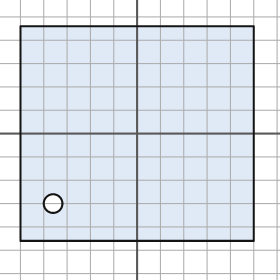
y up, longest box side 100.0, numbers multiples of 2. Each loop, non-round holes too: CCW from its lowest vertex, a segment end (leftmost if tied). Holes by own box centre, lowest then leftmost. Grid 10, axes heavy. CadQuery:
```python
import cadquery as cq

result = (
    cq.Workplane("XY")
    .moveTo(-50.0, -46.0)
    .lineTo(50.0, -46.0)
    .lineTo(50.0, 46.0)
    .lineTo(-50.0, 46.0)
    .close()
    .moveTo(-36.0, -30.0)
    .circle(4.0)
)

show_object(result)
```